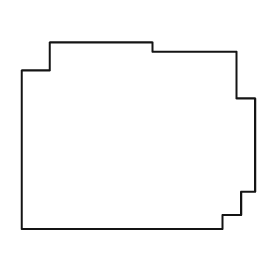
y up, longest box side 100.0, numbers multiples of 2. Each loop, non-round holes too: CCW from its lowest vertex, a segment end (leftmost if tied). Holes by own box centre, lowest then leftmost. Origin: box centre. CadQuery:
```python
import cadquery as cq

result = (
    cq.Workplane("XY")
    .moveTo(-50.0, -40.0)
    .lineTo(36.0, -40.0)
    .lineTo(36.0, -34.0)
    .lineTo(44.0, -34.0)
    .lineTo(44.0, -24.0)
    .lineTo(50.0, -24.0)
    .lineTo(50.0, 16.0)
    .lineTo(42.0, 16.0)
    .lineTo(42.0, 36.0)
    .lineTo(6.0, 36.0)
    .lineTo(6.0, 40.0)
    .lineTo(-38.0, 40.0)
    .lineTo(-38.0, 28.0)
    .lineTo(-50.0, 28.0)
    .close()
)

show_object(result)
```